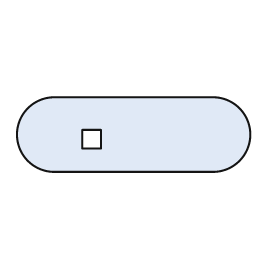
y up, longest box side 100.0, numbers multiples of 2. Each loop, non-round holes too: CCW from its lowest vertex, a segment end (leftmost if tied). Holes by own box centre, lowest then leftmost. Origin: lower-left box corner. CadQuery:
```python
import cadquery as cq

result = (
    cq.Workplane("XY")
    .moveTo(16.0, 0.0)
    .lineTo(84.0, 0.0)
    .threePointArc((100.0, 16.0), (84.0, 32.0))
    .lineTo(16.0, 32.0)
    .threePointArc((0.0, 16.0), (16.0, 0.0))
    .close()
    .moveTo(28.0, 10.0)
    .lineTo(36.0, 10.0)
    .lineTo(36.0, 18.0)
    .lineTo(28.0, 18.0)
    .close()
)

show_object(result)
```